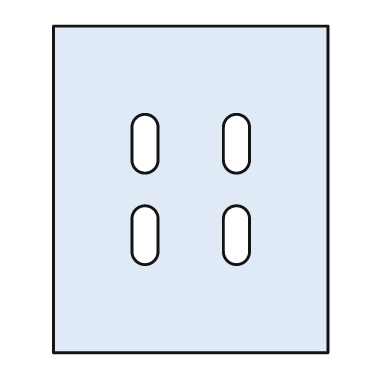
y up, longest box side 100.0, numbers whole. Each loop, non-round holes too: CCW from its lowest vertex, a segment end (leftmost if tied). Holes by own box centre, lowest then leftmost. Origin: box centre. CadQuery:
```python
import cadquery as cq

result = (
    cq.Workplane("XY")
    .moveTo(-42.0, -50.0)
    .lineTo(42.0, -50.0)
    .lineTo(42.0, 50.0)
    .lineTo(-42.0, 50.0)
    .close()
    .moveTo(-18.0, -19.0)
    .threePointArc((-14.0, -23.0), (-10.0, -19.0))
    .lineTo(-10.0, -9.0)
    .threePointArc((-14.0, -5.0), (-18.0, -9.0))
    .close()
    .moveTo(10.0, -19.0)
    .threePointArc((14.0, -23.0), (18.0, -19.0))
    .lineTo(18.0, -9.0)
    .threePointArc((14.0, -5.0), (10.0, -9.0))
    .close()
    .moveTo(-18.0, 9.0)
    .threePointArc((-14.0, 5.0), (-10.0, 9.0))
    .lineTo(-10.0, 19.0)
    .threePointArc((-14.0, 23.0), (-18.0, 19.0))
    .close()
    .moveTo(10.0, 9.0)
    .threePointArc((14.0, 5.0), (18.0, 9.0))
    .lineTo(18.0, 19.0)
    .threePointArc((14.0, 23.0), (10.0, 19.0))
    .close()
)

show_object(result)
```